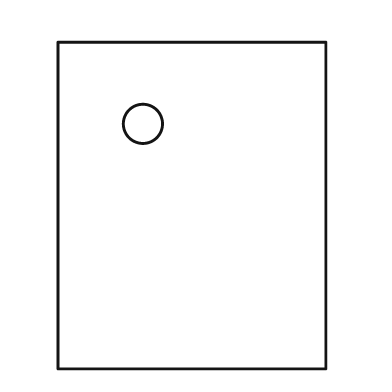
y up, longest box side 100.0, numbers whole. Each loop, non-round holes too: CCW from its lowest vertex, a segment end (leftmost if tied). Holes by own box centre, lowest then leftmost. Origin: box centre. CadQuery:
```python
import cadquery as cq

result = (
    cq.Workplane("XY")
    .moveTo(-41.0, -50.0)
    .lineTo(41.0, -50.0)
    .lineTo(41.0, 50.0)
    .lineTo(-41.0, 50.0)
    .close()
    .moveTo(-15.0, 25.0)
    .circle(6.0)
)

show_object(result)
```